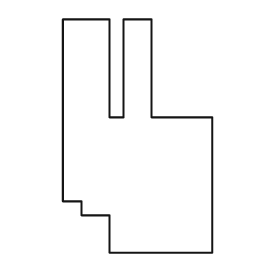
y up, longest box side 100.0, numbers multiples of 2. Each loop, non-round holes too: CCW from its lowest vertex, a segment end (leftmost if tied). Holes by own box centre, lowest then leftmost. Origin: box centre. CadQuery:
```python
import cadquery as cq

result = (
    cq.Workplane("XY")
    .moveTo(-12.0, -50.0)
    .lineTo(32.0, -50.0)
    .lineTo(32.0, 8.0)
    .lineTo(6.0, 8.0)
    .lineTo(6.0, 50.0)
    .lineTo(-6.0, 50.0)
    .lineTo(-6.0, 8.0)
    .lineTo(-12.0, 8.0)
    .lineTo(-12.0, 50.0)
    .lineTo(-32.0, 50.0)
    .lineTo(-32.0, -28.0)
    .lineTo(-24.0, -28.0)
    .lineTo(-24.0, -34.0)
    .lineTo(-12.0, -34.0)
    .close()
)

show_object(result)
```